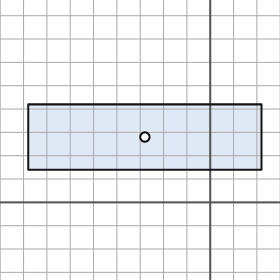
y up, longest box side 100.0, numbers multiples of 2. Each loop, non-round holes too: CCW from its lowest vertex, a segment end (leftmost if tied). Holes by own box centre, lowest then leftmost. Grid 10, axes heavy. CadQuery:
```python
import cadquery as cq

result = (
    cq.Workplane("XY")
    .moveTo(-78.0, 14.0)
    .lineTo(22.0, 14.0)
    .lineTo(22.0, 42.0)
    .lineTo(-78.0, 42.0)
    .close()
    .moveTo(-28.0, 28.0)
    .circle(2.0)
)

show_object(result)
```